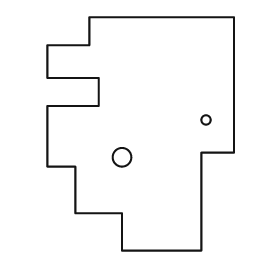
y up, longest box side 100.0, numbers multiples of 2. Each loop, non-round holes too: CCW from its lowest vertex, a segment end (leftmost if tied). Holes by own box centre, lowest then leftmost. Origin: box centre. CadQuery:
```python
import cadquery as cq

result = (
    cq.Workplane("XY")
    .moveTo(-8.0, -50.0)
    .lineTo(26.0, -50.0)
    .lineTo(26.0, -8.0)
    .lineTo(40.0, -8.0)
    .lineTo(40.0, 50.0)
    .lineTo(-22.0, 50.0)
    .lineTo(-22.0, 38.0)
    .lineTo(-40.0, 38.0)
    .lineTo(-40.0, 24.0)
    .lineTo(-18.0, 24.0)
    .lineTo(-18.0, 12.0)
    .lineTo(-40.0, 12.0)
    .lineTo(-40.0, -14.0)
    .lineTo(-28.0, -14.0)
    .lineTo(-28.0, -34.0)
    .lineTo(-8.0, -34.0)
    .close()
    .moveTo(-8.0, -10.0)
    .circle(4.0)
    .moveTo(28.0, 6.0)
    .circle(2.0)
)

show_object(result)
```